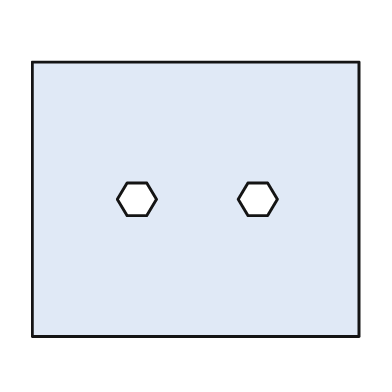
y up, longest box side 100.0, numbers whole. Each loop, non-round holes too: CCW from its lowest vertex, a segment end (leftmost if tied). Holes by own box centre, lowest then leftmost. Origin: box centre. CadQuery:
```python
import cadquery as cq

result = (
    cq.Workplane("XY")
    .moveTo(-50.0, -42.0)
    .lineTo(50.0, -42.0)
    .lineTo(50.0, 42.0)
    .lineTo(-50.0, 42.0)
    .close()
    .moveTo(-21.0, -5.0)
    .lineTo(-15.0, -5.0)
    .lineTo(-12.0, 0.0)
    .lineTo(-15.0, 5.0)
    .lineTo(-21.0, 5.0)
    .lineTo(-24.0, 0.0)
    .close()
    .moveTo(16.0, -5.0)
    .lineTo(22.0, -5.0)
    .lineTo(25.0, 0.0)
    .lineTo(22.0, 5.0)
    .lineTo(16.0, 5.0)
    .lineTo(13.0, 0.0)
    .close()
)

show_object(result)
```